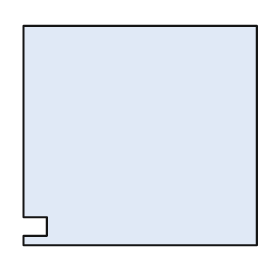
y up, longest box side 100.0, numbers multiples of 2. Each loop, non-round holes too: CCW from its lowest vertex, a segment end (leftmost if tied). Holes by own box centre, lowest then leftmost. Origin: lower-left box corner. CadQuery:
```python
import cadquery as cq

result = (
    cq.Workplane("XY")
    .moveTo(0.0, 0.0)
    .lineTo(100.0, 0.0)
    .lineTo(100.0, 94.0)
    .lineTo(0.0, 94.0)
    .lineTo(0.0, 12.0)
    .lineTo(10.0, 12.0)
    .lineTo(10.0, 4.0)
    .lineTo(0.0, 4.0)
    .close()
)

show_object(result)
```